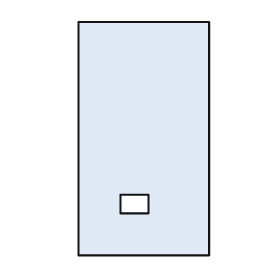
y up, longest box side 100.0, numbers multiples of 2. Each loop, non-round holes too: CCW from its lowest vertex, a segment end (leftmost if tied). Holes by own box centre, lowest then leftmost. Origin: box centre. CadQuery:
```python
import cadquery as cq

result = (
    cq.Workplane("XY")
    .moveTo(-28.0, -50.0)
    .lineTo(28.0, -50.0)
    .lineTo(28.0, 50.0)
    .lineTo(-28.0, 50.0)
    .close()
    .moveTo(-10.0, -32.0)
    .lineTo(2.0, -32.0)
    .lineTo(2.0, -24.0)
    .lineTo(-10.0, -24.0)
    .close()
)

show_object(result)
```